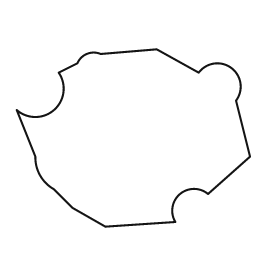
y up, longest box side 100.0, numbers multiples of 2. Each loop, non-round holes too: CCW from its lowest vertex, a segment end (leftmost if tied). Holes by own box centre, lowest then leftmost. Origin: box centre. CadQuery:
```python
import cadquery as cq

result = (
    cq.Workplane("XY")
    .moveTo(-12.0, -38.0)
    .lineTo(18.0, -36.0)
    .threePointArc((20.0, -24.0), (32.0, -24.0))
    .lineTo(50.0, -8.0)
    .lineTo(44.0, 16.0)
    .threePointArc((42.0, 30.0), (28.0, 28.0))
    .lineTo(10.0, 38.0)
    .lineTo(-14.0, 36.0)
    .threePointArc((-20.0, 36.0), (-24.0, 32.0))
    .lineTo(-32.0, 28.0)
    .threePointArc((-34.0, 12.0), (-50.0, 12.0))
    .lineTo(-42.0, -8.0)
    .threePointArc((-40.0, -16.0), (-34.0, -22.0))
    .lineTo(-26.0, -30.0)
    .close()
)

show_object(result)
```